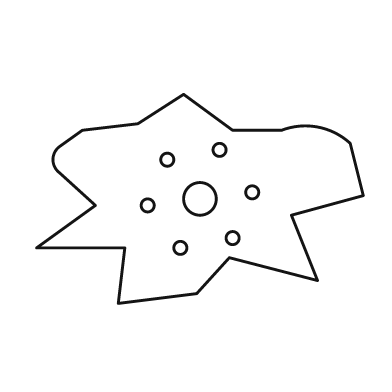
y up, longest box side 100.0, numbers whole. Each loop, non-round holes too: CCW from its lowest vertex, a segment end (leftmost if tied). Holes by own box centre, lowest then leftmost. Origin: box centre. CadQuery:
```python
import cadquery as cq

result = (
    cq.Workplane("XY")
    .moveTo(-25.0, -32.0)
    .lineTo(-1.0, -29.0)
    .lineTo(9.0, -18.0)
    .lineTo(36.0, -25.0)
    .lineTo(28.0, -5.0)
    .lineTo(50.0, 1.0)
    .lineTo(46.0, 17.0)
    .threePointArc((36.0, 22.0), (25.0, 21.0))
    .lineTo(10.0, 21.0)
    .lineTo(-5.0, 32.0)
    .lineTo(-19.0, 23.0)
    .lineTo(-36.0, 21.0)
    .lineTo(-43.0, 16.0)
    .threePointArc((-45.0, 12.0), (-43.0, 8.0))
    .lineTo(-32.0, -2.0)
    .lineTo(-50.0, -15.0)
    .lineTo(-23.0, -15.0)
    .close()
    .moveTo(-6.0, -15.0)
    .circle(2.0)
    .moveTo(10.0, -12.0)
    .circle(2.0)
    .moveTo(-16.0, -2.0)
    .circle(2.0)
    .moveTo(0.0, 0.0)
    .circle(5.0)
    .moveTo(16.0, 2.0)
    .circle(2.0)
    .moveTo(-10.0, 12.0)
    .circle(2.0)
    .moveTo(6.0, 15.0)
    .circle(2.0)
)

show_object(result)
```